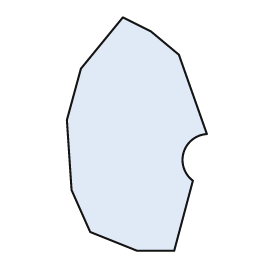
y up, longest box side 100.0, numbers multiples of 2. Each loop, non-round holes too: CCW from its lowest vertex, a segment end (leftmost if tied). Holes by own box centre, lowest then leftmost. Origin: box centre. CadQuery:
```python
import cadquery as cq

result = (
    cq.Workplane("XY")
    .moveTo(0.0, -50.0)
    .lineTo(16.0, -50.0)
    .lineTo(24.0, -20.0)
    .threePointArc((20.0, -8.0), (30.0, 0.0))
    .lineTo(18.0, 34.0)
    .lineTo(6.0, 44.0)
    .lineTo(-6.0, 50.0)
    .lineTo(-24.0, 28.0)
    .lineTo(-30.0, 6.0)
    .lineTo(-28.0, -24.0)
    .lineTo(-20.0, -42.0)
    .close()
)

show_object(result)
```